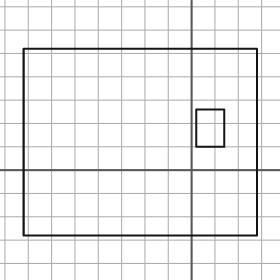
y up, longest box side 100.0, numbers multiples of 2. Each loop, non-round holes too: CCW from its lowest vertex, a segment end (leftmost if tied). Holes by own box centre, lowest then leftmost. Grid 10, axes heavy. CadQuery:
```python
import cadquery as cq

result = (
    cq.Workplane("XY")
    .moveTo(-72.0, -28.0)
    .lineTo(28.0, -28.0)
    .lineTo(28.0, 52.0)
    .lineTo(-72.0, 52.0)
    .close()
    .moveTo(2.0, 10.0)
    .lineTo(14.0, 10.0)
    .lineTo(14.0, 26.0)
    .lineTo(2.0, 26.0)
    .close()
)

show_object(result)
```